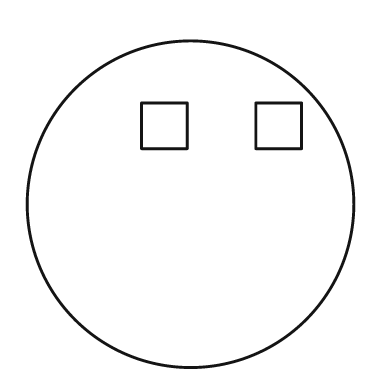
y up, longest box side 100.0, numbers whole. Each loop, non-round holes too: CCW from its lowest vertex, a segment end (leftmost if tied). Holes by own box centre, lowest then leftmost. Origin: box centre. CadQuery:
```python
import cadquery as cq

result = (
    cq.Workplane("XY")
    .moveTo(0.0, 0.0)
    .circle(50.0)
    .moveTo(-15.0, 17.0)
    .lineTo(-1.0, 17.0)
    .lineTo(-1.0, 31.0)
    .lineTo(-15.0, 31.0)
    .close()
    .moveTo(20.0, 17.0)
    .lineTo(34.0, 17.0)
    .lineTo(34.0, 31.0)
    .lineTo(20.0, 31.0)
    .close()
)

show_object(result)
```